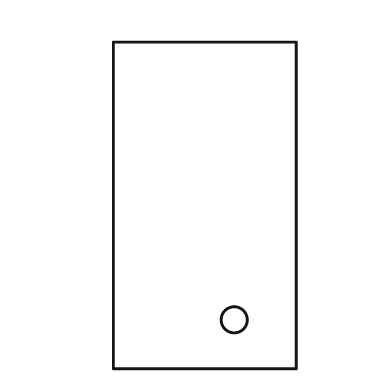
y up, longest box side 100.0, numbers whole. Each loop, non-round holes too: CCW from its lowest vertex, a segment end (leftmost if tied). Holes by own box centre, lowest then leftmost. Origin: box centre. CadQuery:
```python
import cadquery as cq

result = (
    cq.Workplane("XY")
    .moveTo(-28.0, -50.0)
    .lineTo(28.0, -50.0)
    .lineTo(28.0, 50.0)
    .lineTo(-28.0, 50.0)
    .close()
    .moveTo(9.0, -35.0)
    .circle(4.0)
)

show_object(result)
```